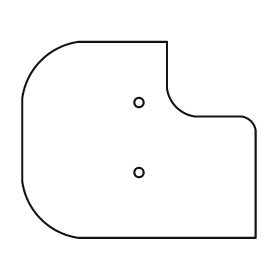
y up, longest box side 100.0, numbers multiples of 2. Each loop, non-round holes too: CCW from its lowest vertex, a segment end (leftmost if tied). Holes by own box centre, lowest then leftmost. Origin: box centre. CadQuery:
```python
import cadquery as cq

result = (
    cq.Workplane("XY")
    .moveTo(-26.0, -42.0)
    .lineTo(50.0, -42.0)
    .lineTo(50.0, 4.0)
    .threePointArc((48.0, 8.0), (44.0, 10.0))
    .lineTo(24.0, 10.0)
    .threePointArc((16.0, 14.0), (12.0, 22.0))
    .lineTo(12.0, 42.0)
    .lineTo(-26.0, 42.0)
    .threePointArc((-42.0, 34.0), (-50.0, 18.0))
    .lineTo(-50.0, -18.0)
    .threePointArc((-42.0, -34.0), (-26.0, -42.0))
    .close()
    .moveTo(0.0, -14.0)
    .circle(2.0)
    .moveTo(0.0, 16.0)
    .circle(2.0)
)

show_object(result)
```